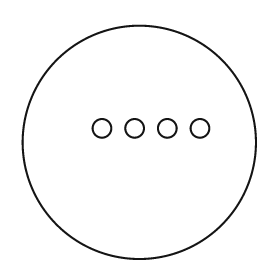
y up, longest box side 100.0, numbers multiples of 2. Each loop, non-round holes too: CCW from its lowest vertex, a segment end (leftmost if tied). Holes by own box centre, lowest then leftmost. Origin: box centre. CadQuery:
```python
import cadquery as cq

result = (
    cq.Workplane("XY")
    .moveTo(0.0, 0.0)
    .circle(50.0)
    .moveTo(-16.0, 6.0)
    .circle(4.0)
    .moveTo(-2.0, 6.0)
    .circle(4.0)
    .moveTo(12.0, 6.0)
    .circle(4.0)
    .moveTo(26.0, 6.0)
    .circle(4.0)
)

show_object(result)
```